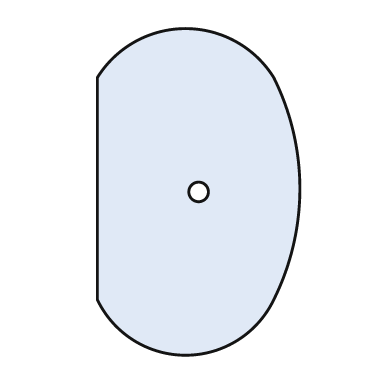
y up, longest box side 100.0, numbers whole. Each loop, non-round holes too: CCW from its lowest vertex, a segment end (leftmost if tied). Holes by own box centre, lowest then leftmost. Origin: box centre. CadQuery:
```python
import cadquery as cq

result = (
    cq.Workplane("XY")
    .moveTo(-31.0, -33.0)
    .threePointArc((-4.0, -50.0), (23.0, -33.0))
    .threePointArc((31.0, 1.0), (23.0, 35.0))
    .threePointArc((-4.0, 50.0), (-31.0, 35.0))
    .close()
    .moveTo(0.0, 0.0)
    .circle(3.0)
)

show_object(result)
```